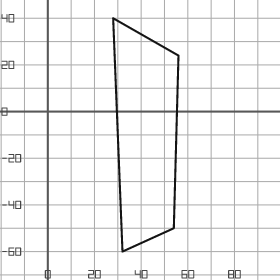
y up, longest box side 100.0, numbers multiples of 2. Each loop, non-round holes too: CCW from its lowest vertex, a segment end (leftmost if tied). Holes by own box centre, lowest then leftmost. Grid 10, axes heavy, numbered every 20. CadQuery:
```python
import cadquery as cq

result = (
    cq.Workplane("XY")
    .moveTo(32.0, -60.0)
    .lineTo(54.0, -50.0)
    .lineTo(56.0, 24.0)
    .lineTo(28.0, 40.0)
    .close()
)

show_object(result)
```